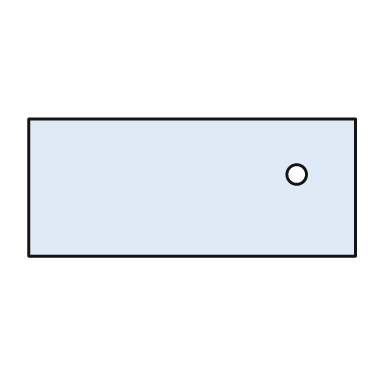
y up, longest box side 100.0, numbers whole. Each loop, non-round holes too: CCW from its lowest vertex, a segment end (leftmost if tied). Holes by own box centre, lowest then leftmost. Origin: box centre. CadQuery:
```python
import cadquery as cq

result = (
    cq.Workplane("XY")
    .moveTo(-50.0, -21.0)
    .lineTo(50.0, -21.0)
    .lineTo(50.0, 21.0)
    .lineTo(-50.0, 21.0)
    .close()
    .moveTo(32.0, 4.0)
    .circle(3.0)
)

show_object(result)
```